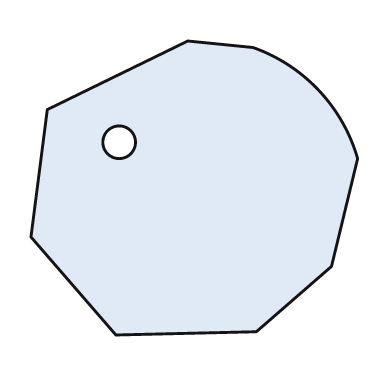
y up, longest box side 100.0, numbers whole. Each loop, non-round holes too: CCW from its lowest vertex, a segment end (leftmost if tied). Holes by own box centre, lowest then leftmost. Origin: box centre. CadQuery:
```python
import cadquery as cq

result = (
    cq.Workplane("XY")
    .moveTo(-24.0, -45.0)
    .lineTo(19.0, -44.0)
    .lineTo(42.0, -24.0)
    .lineTo(50.0, 9.0)
    .threePointArc((38.0, 30.0), (18.0, 43.0))
    .lineTo(-2.0, 45.0)
    .lineTo(-45.0, 24.0)
    .lineTo(-50.0, -15.0)
    .close()
    .moveTo(-23.0, 14.0)
    .circle(5.0)
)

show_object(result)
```